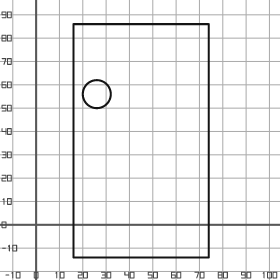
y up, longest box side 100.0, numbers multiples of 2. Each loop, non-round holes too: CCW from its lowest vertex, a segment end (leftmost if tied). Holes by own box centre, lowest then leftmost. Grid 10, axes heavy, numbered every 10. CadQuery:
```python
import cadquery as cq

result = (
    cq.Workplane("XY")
    .moveTo(16.0, -14.0)
    .lineTo(74.0, -14.0)
    .lineTo(74.0, 86.0)
    .lineTo(16.0, 86.0)
    .close()
    .moveTo(26.0, 56.0)
    .circle(6.0)
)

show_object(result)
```